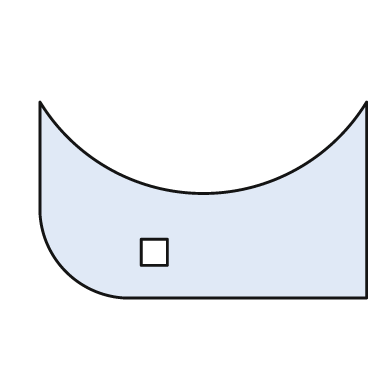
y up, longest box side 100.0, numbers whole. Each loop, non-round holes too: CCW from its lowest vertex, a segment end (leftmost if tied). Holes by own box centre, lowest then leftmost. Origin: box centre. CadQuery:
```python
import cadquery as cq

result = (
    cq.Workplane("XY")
    .moveTo(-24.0, -30.0)
    .lineTo(50.0, -30.0)
    .lineTo(50.0, 30.0)
    .threePointArc((0.0, 2.0), (-50.0, 30.0))
    .lineTo(-50.0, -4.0)
    .threePointArc((-42.0, -22.0), (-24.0, -30.0))
    .close()
    .moveTo(-19.0, -20.0)
    .lineTo(-11.0, -20.0)
    .lineTo(-11.0, -12.0)
    .lineTo(-19.0, -12.0)
    .close()
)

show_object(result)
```